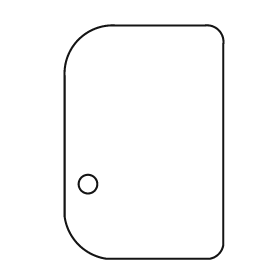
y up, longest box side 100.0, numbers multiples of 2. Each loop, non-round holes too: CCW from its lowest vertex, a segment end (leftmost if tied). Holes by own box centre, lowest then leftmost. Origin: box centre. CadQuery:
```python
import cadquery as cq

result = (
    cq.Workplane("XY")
    .moveTo(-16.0, -50.0)
    .lineTo(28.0, -50.0)
    .threePointArc((32.0, -48.0), (34.0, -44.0))
    .lineTo(34.0, 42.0)
    .threePointArc((32.0, 48.0), (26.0, 50.0))
    .lineTo(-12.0, 50.0)
    .threePointArc((-28.0, 44.0), (-34.0, 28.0))
    .lineTo(-34.0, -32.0)
    .threePointArc((-28.0, -44.0), (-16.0, -50.0))
    .close()
    .moveTo(-24.0, -18.0)
    .circle(4.0)
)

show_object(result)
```